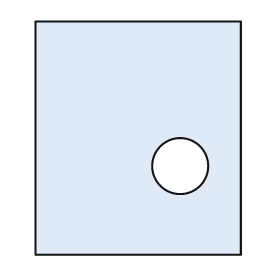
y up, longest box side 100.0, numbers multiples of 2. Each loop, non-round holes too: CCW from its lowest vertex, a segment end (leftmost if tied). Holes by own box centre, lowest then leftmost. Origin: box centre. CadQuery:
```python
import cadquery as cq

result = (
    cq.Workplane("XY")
    .moveTo(-44.0, -50.0)
    .lineTo(44.0, -50.0)
    .lineTo(44.0, 50.0)
    .lineTo(-44.0, 50.0)
    .close()
    .moveTo(18.0, -12.0)
    .circle(12.0)
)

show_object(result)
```